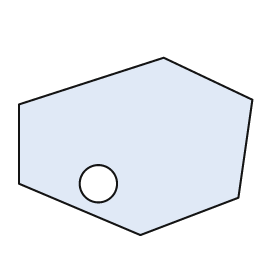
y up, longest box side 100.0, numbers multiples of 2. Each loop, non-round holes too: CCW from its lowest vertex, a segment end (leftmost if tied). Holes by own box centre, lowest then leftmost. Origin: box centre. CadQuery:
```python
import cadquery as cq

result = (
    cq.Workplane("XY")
    .moveTo(2.0, -38.0)
    .lineTo(44.0, -22.0)
    .lineTo(50.0, 20.0)
    .lineTo(12.0, 38.0)
    .lineTo(-50.0, 18.0)
    .lineTo(-50.0, -16.0)
    .close()
    .moveTo(-16.0, -16.0)
    .circle(8.0)
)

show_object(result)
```